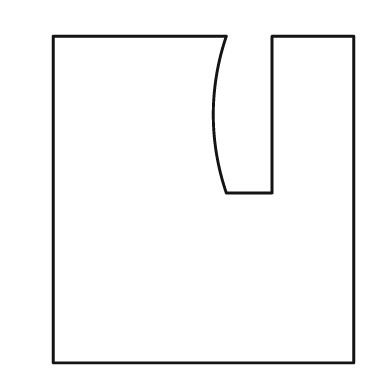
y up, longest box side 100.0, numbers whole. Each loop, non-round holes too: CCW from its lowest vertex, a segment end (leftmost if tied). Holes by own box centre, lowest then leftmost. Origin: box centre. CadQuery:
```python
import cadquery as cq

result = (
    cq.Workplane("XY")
    .moveTo(-46.0, -50.0)
    .lineTo(46.0, -50.0)
    .lineTo(46.0, 50.0)
    .lineTo(21.0, 50.0)
    .lineTo(21.0, 2.0)
    .lineTo(7.0, 2.0)
    .threePointArc((3.0, 26.0), (7.0, 50.0))
    .lineTo(-46.0, 50.0)
    .close()
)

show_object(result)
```